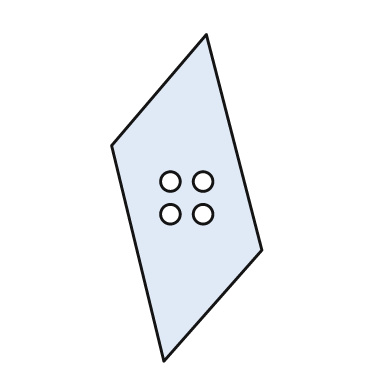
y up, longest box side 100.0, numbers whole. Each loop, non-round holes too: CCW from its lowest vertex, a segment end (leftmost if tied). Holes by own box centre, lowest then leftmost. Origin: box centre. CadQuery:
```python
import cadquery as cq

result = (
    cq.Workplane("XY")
    .moveTo(-7.0, -50.0)
    .lineTo(23.0, -16.0)
    .lineTo(6.0, 50.0)
    .lineTo(-23.0, 16.0)
    .close()
    .moveTo(-5.0, -5.0)
    .circle(3.0)
    .moveTo(5.0, -5.0)
    .circle(3.0)
    .moveTo(-5.0, 5.0)
    .circle(3.0)
    .moveTo(5.0, 5.0)
    .circle(3.0)
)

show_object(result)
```